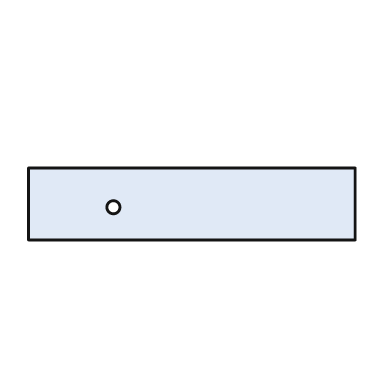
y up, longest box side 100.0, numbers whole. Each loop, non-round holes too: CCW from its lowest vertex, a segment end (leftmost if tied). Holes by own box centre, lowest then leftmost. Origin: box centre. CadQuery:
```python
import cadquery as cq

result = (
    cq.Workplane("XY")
    .moveTo(-50.0, -11.0)
    .lineTo(50.0, -11.0)
    .lineTo(50.0, 11.0)
    .lineTo(-50.0, 11.0)
    .close()
    .moveTo(-24.0, -1.0)
    .circle(2.0)
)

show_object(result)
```